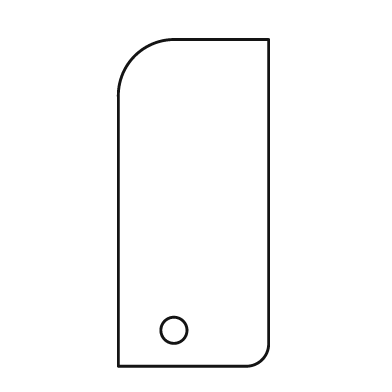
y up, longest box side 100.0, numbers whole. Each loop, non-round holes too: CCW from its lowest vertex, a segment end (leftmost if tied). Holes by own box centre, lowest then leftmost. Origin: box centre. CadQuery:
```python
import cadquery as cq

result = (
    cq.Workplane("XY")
    .moveTo(-23.0, -50.0)
    .lineTo(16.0, -50.0)
    .threePointArc((21.0, -48.0), (23.0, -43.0))
    .lineTo(23.0, 50.0)
    .lineTo(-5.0, 50.0)
    .threePointArc((-18.0, 45.0), (-23.0, 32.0))
    .close()
    .moveTo(-6.0, -39.0)
    .circle(4.0)
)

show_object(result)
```